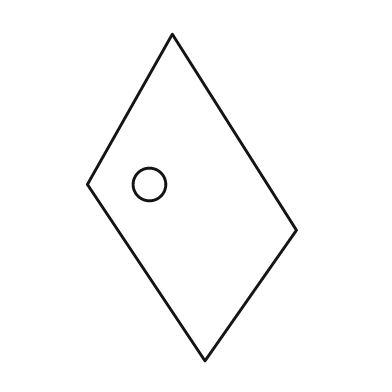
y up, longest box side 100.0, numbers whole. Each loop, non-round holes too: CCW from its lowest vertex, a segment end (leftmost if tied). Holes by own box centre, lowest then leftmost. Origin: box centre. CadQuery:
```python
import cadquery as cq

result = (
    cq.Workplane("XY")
    .moveTo(4.0, -50.0)
    .lineTo(32.0, -10.0)
    .lineTo(-6.0, 50.0)
    .lineTo(-32.0, 4.0)
    .close()
    .moveTo(-13.0, 4.0)
    .circle(5.0)
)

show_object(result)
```